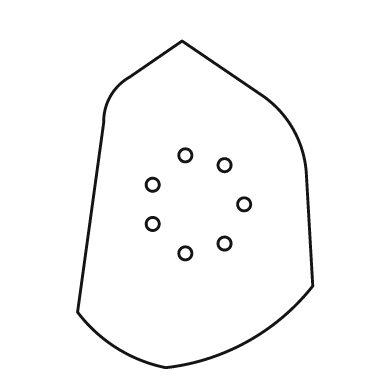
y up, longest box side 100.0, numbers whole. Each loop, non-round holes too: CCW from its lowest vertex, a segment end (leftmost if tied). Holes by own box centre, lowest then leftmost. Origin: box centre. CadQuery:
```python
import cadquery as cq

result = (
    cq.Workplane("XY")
    .moveTo(-9.0, -50.0)
    .threePointArc((16.0, -42.0), (36.0, -25.0))
    .lineTo(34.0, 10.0)
    .threePointArc((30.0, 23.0), (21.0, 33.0))
    .lineTo(-4.0, 50.0)
    .lineTo(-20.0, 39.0)
    .threePointArc((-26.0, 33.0), (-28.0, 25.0))
    .lineTo(-36.0, -33.0)
    .threePointArc((-24.0, -44.0), (-9.0, -50.0))
    .close()
    .moveTo(-3.0, -15.0)
    .circle(2.0)
    .moveTo(9.0, -12.0)
    .circle(2.0)
    .moveTo(-13.0, -6.0)
    .circle(2.0)
    .moveTo(15.0, 0.0)
    .circle(2.0)
    .moveTo(-13.0, 6.0)
    .circle(2.0)
    .moveTo(9.0, 12.0)
    .circle(2.0)
    .moveTo(-3.0, 15.0)
    .circle(2.0)
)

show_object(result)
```